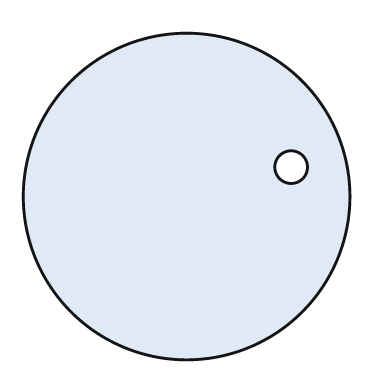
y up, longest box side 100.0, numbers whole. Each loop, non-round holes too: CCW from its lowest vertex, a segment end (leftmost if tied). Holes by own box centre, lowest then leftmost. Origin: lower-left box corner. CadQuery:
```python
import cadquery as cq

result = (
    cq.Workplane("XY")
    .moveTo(50.0, 50.0)
    .circle(50.0)
    .moveTo(82.0, 59.0)
    .circle(5.0)
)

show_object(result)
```